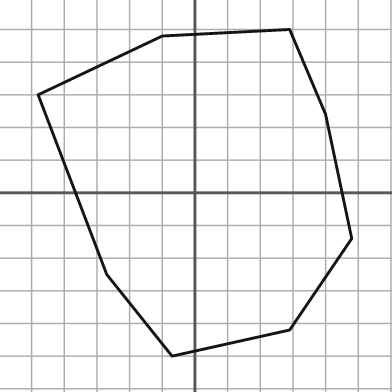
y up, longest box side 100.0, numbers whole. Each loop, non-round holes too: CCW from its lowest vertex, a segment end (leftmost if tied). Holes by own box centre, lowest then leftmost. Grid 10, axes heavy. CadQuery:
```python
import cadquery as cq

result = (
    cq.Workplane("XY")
    .moveTo(-7.0, -50.0)
    .lineTo(29.0, -42.0)
    .lineTo(48.0, -14.0)
    .lineTo(40.0, 24.0)
    .lineTo(29.0, 50.0)
    .lineTo(-10.0, 48.0)
    .lineTo(-48.0, 30.0)
    .lineTo(-27.0, -25.0)
    .close()
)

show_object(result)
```